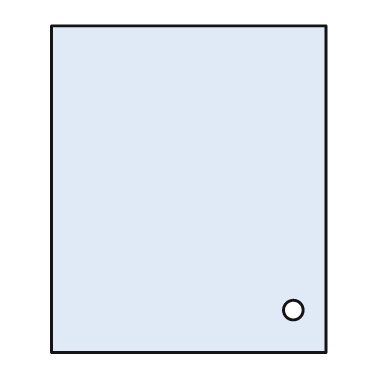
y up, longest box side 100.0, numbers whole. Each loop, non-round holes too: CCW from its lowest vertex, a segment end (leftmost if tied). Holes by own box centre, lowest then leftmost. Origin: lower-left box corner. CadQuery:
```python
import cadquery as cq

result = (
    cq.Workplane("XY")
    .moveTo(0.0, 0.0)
    .lineTo(84.0, 0.0)
    .lineTo(84.0, 100.0)
    .lineTo(0.0, 100.0)
    .close()
    .moveTo(74.0, 13.0)
    .circle(3.0)
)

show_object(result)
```